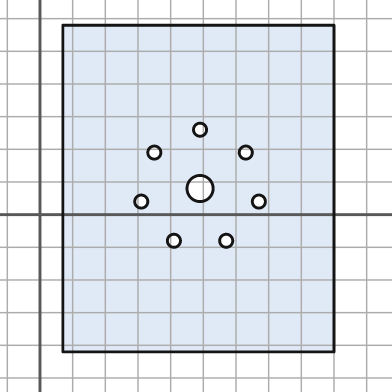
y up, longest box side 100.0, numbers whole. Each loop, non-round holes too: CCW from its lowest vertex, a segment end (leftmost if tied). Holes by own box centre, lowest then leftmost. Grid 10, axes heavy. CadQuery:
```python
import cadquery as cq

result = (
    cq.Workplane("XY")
    .moveTo(7.0, -42.0)
    .lineTo(90.0, -42.0)
    .lineTo(90.0, 58.0)
    .lineTo(7.0, 58.0)
    .close()
    .moveTo(41.0, -8.0)
    .circle(2.0)
    .moveTo(57.0, -8.0)
    .circle(2.0)
    .moveTo(31.0, 4.0)
    .circle(2.0)
    .moveTo(67.0, 4.0)
    .circle(2.0)
    .moveTo(49.0, 8.0)
    .circle(4.0)
    .moveTo(35.0, 19.0)
    .circle(2.0)
    .moveTo(63.0, 19.0)
    .circle(2.0)
    .moveTo(49.0, 26.0)
    .circle(2.0)
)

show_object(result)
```